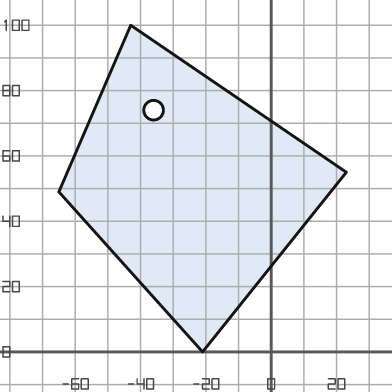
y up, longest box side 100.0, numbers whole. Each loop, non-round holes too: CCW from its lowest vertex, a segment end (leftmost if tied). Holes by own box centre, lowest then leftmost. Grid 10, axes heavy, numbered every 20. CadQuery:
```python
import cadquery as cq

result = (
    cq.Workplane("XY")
    .moveTo(-21.0, 0.0)
    .lineTo(23.0, 55.0)
    .lineTo(-43.0, 100.0)
    .lineTo(-65.0, 49.0)
    .close()
    .moveTo(-36.0, 74.0)
    .circle(3.0)
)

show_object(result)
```